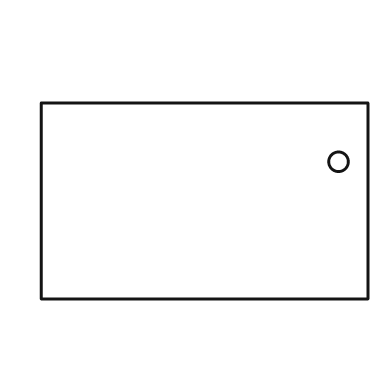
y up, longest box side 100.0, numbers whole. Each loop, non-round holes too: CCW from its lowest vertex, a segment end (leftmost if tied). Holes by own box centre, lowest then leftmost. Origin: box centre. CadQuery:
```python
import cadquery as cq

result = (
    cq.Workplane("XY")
    .moveTo(-50.0, -30.0)
    .lineTo(50.0, -30.0)
    .lineTo(50.0, 30.0)
    .lineTo(-50.0, 30.0)
    .close()
    .moveTo(41.0, 12.0)
    .circle(3.0)
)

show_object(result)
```